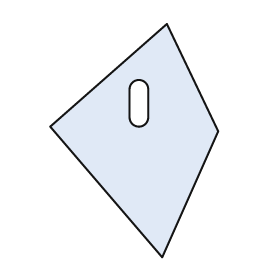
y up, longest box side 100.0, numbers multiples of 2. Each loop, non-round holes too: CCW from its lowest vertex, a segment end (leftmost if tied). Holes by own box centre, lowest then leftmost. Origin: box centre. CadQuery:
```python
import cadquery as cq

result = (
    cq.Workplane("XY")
    .moveTo(12.0, -50.0)
    .lineTo(36.0, 4.0)
    .lineTo(14.0, 50.0)
    .lineTo(-36.0, 6.0)
    .close()
    .moveTo(-2.0, 10.0)
    .threePointArc((2.0, 6.0), (6.0, 10.0))
    .lineTo(6.0, 22.0)
    .threePointArc((2.0, 26.0), (-2.0, 22.0))
    .close()
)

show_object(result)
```